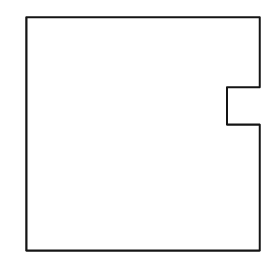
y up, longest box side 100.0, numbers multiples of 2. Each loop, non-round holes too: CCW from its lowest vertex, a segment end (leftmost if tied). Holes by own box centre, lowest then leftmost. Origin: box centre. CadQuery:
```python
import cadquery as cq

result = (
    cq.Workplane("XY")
    .moveTo(-50.0, -50.0)
    .lineTo(50.0, -50.0)
    .lineTo(50.0, 4.0)
    .lineTo(36.0, 4.0)
    .lineTo(36.0, 20.0)
    .lineTo(50.0, 20.0)
    .lineTo(50.0, 50.0)
    .lineTo(-50.0, 50.0)
    .close()
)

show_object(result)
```